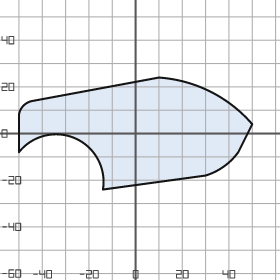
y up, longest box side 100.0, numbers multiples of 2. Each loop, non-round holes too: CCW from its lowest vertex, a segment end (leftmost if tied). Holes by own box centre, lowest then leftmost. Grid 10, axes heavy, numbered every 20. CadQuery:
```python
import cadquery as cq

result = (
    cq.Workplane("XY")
    .moveTo(-14.0, -24.0)
    .lineTo(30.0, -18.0)
    .threePointArc((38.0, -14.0), (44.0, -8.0))
    .lineTo(50.0, 4.0)
    .threePointArc((32.0, 18.0), (10.0, 24.0))
    .lineTo(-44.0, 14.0)
    .threePointArc((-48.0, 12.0), (-50.0, 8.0))
    .lineTo(-50.0, -8.0)
    .threePointArc((-26.0, -2.0), (-14.0, -24.0))
    .close()
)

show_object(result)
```